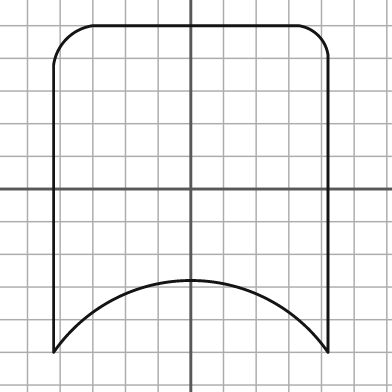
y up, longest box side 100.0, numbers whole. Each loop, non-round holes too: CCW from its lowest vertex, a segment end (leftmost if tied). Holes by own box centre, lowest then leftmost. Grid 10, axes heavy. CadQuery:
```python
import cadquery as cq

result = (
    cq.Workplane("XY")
    .moveTo(-42.0, -50.0)
    .threePointArc((0.0, -28.0), (42.0, -50.0))
    .lineTo(42.0, 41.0)
    .threePointArc((39.0, 47.0), (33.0, 50.0))
    .lineTo(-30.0, 50.0)
    .threePointArc((-38.0, 46.0), (-42.0, 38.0))
    .close()
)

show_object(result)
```